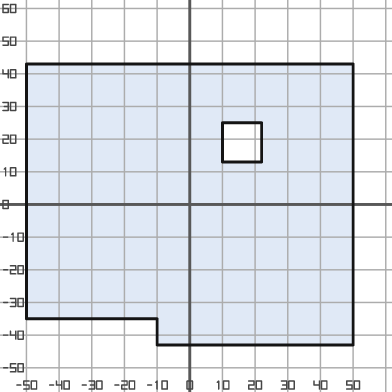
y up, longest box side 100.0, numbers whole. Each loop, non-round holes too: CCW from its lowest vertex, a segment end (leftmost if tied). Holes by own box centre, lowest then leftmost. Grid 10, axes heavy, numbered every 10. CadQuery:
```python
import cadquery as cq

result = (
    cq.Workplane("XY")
    .moveTo(-10.0, -43.0)
    .lineTo(50.0, -43.0)
    .lineTo(50.0, 43.0)
    .lineTo(-50.0, 43.0)
    .lineTo(-50.0, -35.0)
    .lineTo(-10.0, -35.0)
    .close()
    .moveTo(10.0, 13.0)
    .lineTo(22.0, 13.0)
    .lineTo(22.0, 25.0)
    .lineTo(10.0, 25.0)
    .close()
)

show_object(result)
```